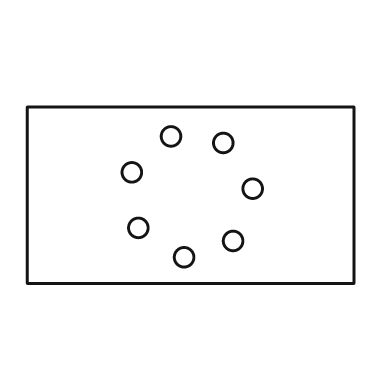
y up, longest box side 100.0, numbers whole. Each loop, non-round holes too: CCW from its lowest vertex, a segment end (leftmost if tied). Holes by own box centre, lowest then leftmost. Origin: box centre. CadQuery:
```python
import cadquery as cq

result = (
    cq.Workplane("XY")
    .moveTo(-50.0, -27.0)
    .lineTo(50.0, -27.0)
    .lineTo(50.0, 27.0)
    .lineTo(-50.0, 27.0)
    .close()
    .moveTo(-2.0, -19.0)
    .circle(3.0)
    .moveTo(13.0, -14.0)
    .circle(3.0)
    .moveTo(-16.0, -10.0)
    .circle(3.0)
    .moveTo(19.0, 2.0)
    .circle(3.0)
    .moveTo(-18.0, 7.0)
    .circle(3.0)
    .moveTo(10.0, 16.0)
    .circle(3.0)
    .moveTo(-6.0, 18.0)
    .circle(3.0)
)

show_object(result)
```